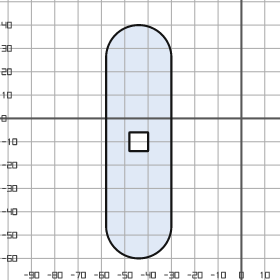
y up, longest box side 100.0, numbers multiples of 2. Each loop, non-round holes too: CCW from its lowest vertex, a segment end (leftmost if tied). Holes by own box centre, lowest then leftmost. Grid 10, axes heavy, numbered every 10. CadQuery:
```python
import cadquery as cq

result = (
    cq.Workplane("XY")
    .moveTo(-58.0, -46.0)
    .threePointArc((-44.0, -60.0), (-30.0, -46.0))
    .lineTo(-30.0, 26.0)
    .threePointArc((-44.0, 40.0), (-58.0, 26.0))
    .close()
    .moveTo(-48.0, -14.0)
    .lineTo(-40.0, -14.0)
    .lineTo(-40.0, -6.0)
    .lineTo(-48.0, -6.0)
    .close()
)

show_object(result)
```